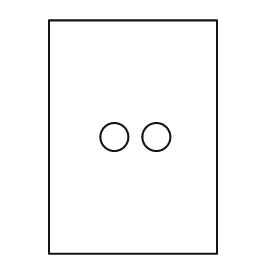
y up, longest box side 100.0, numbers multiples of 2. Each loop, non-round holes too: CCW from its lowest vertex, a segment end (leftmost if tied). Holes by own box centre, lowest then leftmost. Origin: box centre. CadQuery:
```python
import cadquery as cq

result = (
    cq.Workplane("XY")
    .moveTo(-36.0, -50.0)
    .lineTo(36.0, -50.0)
    .lineTo(36.0, 50.0)
    .lineTo(-36.0, 50.0)
    .close()
    .moveTo(-8.0, 0.0)
    .circle(6.0)
    .moveTo(10.0, 0.0)
    .circle(6.0)
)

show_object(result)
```